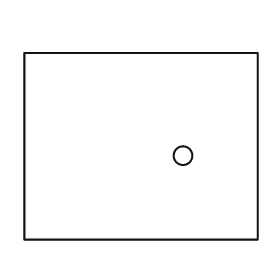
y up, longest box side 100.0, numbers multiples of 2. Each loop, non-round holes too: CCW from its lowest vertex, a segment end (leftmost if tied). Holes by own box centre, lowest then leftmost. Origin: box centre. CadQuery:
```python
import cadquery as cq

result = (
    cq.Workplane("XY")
    .moveTo(-50.0, -40.0)
    .lineTo(50.0, -40.0)
    .lineTo(50.0, 40.0)
    .lineTo(-50.0, 40.0)
    .close()
    .moveTo(18.0, -4.0)
    .circle(4.0)
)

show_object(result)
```